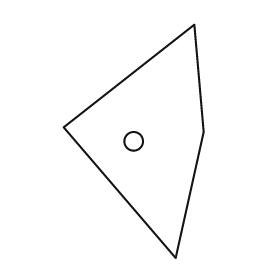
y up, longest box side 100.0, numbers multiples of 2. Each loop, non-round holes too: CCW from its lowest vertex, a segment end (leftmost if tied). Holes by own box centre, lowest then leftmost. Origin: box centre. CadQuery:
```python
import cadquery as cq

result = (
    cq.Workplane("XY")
    .moveTo(18.0, -50.0)
    .lineTo(30.0, 4.0)
    .lineTo(26.0, 50.0)
    .lineTo(-30.0, 6.0)
    .close()
    .moveTo(0.0, 0.0)
    .circle(4.0)
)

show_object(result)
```